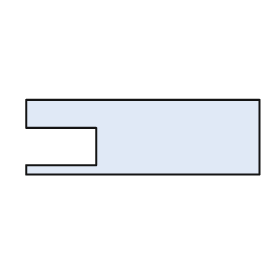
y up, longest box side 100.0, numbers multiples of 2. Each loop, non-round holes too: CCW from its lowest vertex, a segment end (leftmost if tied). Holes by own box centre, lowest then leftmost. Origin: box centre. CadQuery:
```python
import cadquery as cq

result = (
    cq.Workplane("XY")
    .moveTo(-50.0, -16.0)
    .lineTo(50.0, -16.0)
    .lineTo(50.0, 16.0)
    .lineTo(-50.0, 16.0)
    .lineTo(-50.0, 4.0)
    .lineTo(-20.0, 4.0)
    .lineTo(-20.0, -12.0)
    .lineTo(-50.0, -12.0)
    .close()
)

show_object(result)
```